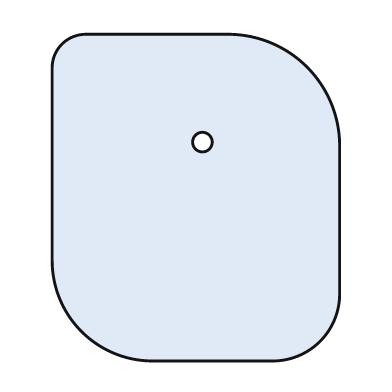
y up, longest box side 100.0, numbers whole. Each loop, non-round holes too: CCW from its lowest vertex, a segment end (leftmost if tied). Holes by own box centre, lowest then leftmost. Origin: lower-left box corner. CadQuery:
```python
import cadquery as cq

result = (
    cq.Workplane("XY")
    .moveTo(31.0, 0.0)
    .lineTo(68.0, 0.0)
    .threePointArc((82.0, 6.0), (88.0, 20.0))
    .lineTo(88.0, 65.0)
    .threePointArc((78.0, 90.0), (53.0, 100.0))
    .lineTo(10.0, 100.0)
    .threePointArc((3.0, 97.0), (0.0, 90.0))
    .lineTo(0.0, 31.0)
    .threePointArc((9.0, 9.0), (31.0, 0.0))
    .close()
    .moveTo(46.0, 67.0)
    .circle(3.0)
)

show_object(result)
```